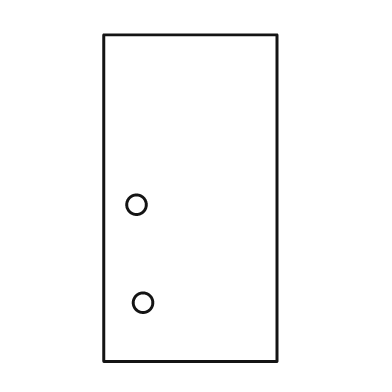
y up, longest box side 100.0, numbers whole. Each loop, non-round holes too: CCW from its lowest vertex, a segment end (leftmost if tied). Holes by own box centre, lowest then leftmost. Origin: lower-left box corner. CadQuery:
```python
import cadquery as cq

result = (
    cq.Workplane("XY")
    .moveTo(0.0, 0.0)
    .lineTo(53.0, 0.0)
    .lineTo(53.0, 100.0)
    .lineTo(0.0, 100.0)
    .close()
    .moveTo(12.0, 18.0)
    .circle(3.0)
    .moveTo(10.0, 48.0)
    .circle(3.0)
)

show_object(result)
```